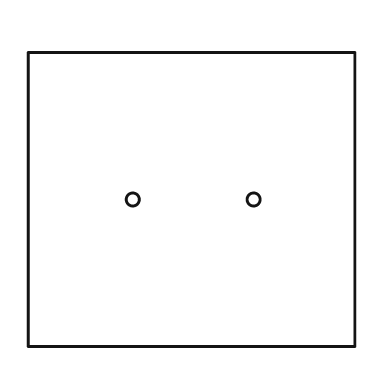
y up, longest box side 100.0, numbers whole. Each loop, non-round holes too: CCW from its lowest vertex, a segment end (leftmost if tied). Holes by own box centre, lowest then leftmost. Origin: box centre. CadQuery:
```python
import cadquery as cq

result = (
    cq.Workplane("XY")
    .moveTo(-50.0, -45.0)
    .lineTo(50.0, -45.0)
    .lineTo(50.0, 45.0)
    .lineTo(-50.0, 45.0)
    .close()
    .moveTo(-18.0, 0.0)
    .circle(2.0)
    .moveTo(19.0, 0.0)
    .circle(2.0)
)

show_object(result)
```